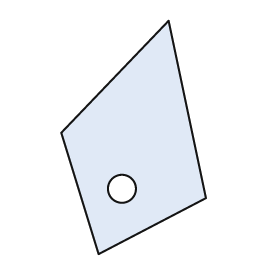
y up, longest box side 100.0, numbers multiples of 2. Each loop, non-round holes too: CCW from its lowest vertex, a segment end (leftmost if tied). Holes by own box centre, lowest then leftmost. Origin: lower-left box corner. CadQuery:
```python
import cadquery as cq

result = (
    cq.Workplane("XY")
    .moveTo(16.0, 0.0)
    .lineTo(62.0, 24.0)
    .lineTo(46.0, 100.0)
    .lineTo(0.0, 52.0)
    .close()
    .moveTo(26.0, 28.0)
    .circle(6.0)
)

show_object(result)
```